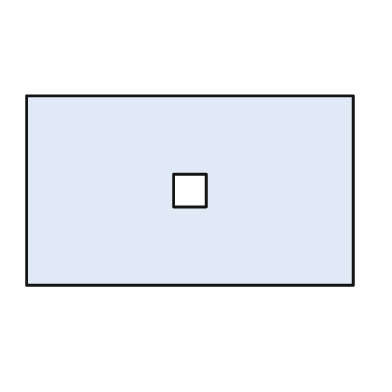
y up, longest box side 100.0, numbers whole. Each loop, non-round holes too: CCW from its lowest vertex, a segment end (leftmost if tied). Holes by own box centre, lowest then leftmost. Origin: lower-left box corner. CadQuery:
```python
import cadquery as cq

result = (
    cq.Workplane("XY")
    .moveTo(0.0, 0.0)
    .lineTo(100.0, 0.0)
    .lineTo(100.0, 58.0)
    .lineTo(0.0, 58.0)
    .close()
    .moveTo(45.0, 24.0)
    .lineTo(55.0, 24.0)
    .lineTo(55.0, 34.0)
    .lineTo(45.0, 34.0)
    .close()
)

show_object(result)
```